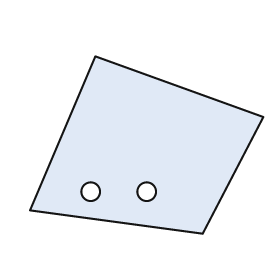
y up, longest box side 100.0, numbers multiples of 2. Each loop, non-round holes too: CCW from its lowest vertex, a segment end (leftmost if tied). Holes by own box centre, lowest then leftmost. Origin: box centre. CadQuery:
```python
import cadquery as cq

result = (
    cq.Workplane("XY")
    .moveTo(24.0, -38.0)
    .lineTo(50.0, 12.0)
    .lineTo(-22.0, 38.0)
    .lineTo(-50.0, -28.0)
    .close()
    .moveTo(-24.0, -20.0)
    .circle(4.0)
    .moveTo(0.0, -20.0)
    .circle(4.0)
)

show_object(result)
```